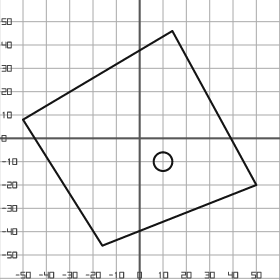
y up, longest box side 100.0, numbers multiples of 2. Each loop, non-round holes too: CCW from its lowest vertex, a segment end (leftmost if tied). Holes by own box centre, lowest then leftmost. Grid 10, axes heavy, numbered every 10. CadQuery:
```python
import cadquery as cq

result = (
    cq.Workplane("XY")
    .moveTo(-16.0, -46.0)
    .lineTo(50.0, -20.0)
    .lineTo(14.0, 46.0)
    .lineTo(-50.0, 8.0)
    .close()
    .moveTo(10.0, -10.0)
    .circle(4.0)
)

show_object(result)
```